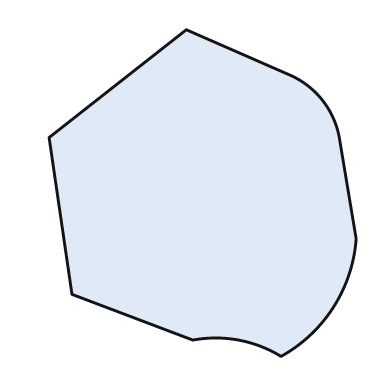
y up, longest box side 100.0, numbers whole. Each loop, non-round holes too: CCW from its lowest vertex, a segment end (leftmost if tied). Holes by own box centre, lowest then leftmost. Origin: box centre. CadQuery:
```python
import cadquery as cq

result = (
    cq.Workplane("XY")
    .moveTo(24.0, -50.0)
    .threePointArc((40.0, -35.0), (47.0, -14.0))
    .lineTo(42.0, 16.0)
    .threePointArc((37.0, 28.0), (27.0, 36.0))
    .lineTo(-5.0, 50.0)
    .lineTo(-47.0, 17.0)
    .lineTo(-40.0, -31.0)
    .lineTo(-3.0, -45.0)
    .threePointArc((11.0, -45.0), (24.0, -50.0))
    .close()
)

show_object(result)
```